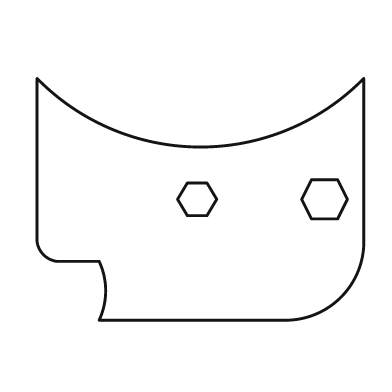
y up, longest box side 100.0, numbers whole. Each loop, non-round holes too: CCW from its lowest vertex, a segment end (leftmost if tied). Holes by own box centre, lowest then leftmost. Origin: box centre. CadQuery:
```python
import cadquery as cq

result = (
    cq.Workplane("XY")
    .moveTo(-31.0, -37.0)
    .lineTo(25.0, -37.0)
    .threePointArc((43.0, -30.0), (50.0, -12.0))
    .lineTo(50.0, 37.0)
    .threePointArc((0.0, 16.0), (-50.0, 37.0))
    .lineTo(-50.0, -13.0)
    .threePointArc((-48.0, -17.0), (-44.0, -19.0))
    .lineTo(-31.0, -19.0)
    .threePointArc((-29.0, -28.0), (-31.0, -37.0))
    .close()
    .moveTo(-4.0, -5.0)
    .lineTo(2.0, -5.0)
    .lineTo(5.0, 0.0)
    .lineTo(2.0, 5.0)
    .lineTo(-4.0, 5.0)
    .lineTo(-7.0, 0.0)
    .close()
    .moveTo(34.0, -6.0)
    .lineTo(42.0, -6.0)
    .lineTo(45.0, 0.0)
    .lineTo(42.0, 6.0)
    .lineTo(34.0, 6.0)
    .lineTo(31.0, 0.0)
    .close()
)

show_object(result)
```